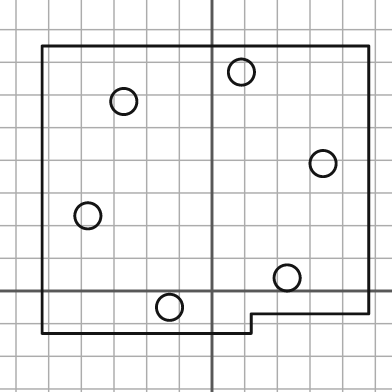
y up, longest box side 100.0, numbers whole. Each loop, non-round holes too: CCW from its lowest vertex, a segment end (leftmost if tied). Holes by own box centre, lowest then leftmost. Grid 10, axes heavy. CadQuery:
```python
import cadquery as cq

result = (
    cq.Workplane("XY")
    .moveTo(-52.0, -13.0)
    .lineTo(12.0, -13.0)
    .lineTo(12.0, -7.0)
    .lineTo(48.0, -7.0)
    .lineTo(48.0, 75.0)
    .lineTo(-52.0, 75.0)
    .close()
    .moveTo(-13.0, -5.0)
    .circle(4.0)
    .moveTo(23.0, 4.0)
    .circle(4.0)
    .moveTo(-38.0, 23.0)
    .circle(4.0)
    .moveTo(34.0, 39.0)
    .circle(4.0)
    .moveTo(-27.0, 58.0)
    .circle(4.0)
    .moveTo(9.0, 67.0)
    .circle(4.0)
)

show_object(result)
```